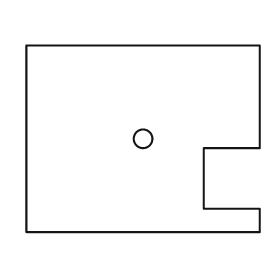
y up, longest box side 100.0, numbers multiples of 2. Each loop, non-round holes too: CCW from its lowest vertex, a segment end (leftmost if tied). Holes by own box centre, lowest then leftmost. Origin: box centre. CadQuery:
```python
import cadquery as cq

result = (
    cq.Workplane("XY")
    .moveTo(-50.0, -40.0)
    .lineTo(50.0, -40.0)
    .lineTo(50.0, -30.0)
    .lineTo(26.0, -30.0)
    .lineTo(26.0, -4.0)
    .lineTo(50.0, -4.0)
    .lineTo(50.0, 40.0)
    .lineTo(-50.0, 40.0)
    .close()
    .moveTo(0.0, 0.0)
    .circle(4.0)
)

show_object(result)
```